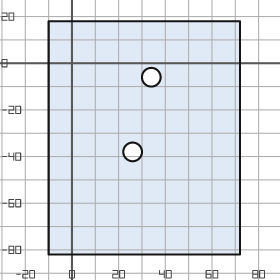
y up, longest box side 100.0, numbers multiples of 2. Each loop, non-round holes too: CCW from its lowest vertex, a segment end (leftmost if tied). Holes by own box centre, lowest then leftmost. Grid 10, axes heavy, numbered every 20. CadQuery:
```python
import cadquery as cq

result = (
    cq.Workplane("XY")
    .moveTo(-10.0, -82.0)
    .lineTo(72.0, -82.0)
    .lineTo(72.0, 18.0)
    .lineTo(-10.0, 18.0)
    .close()
    .moveTo(26.0, -38.0)
    .circle(4.0)
    .moveTo(34.0, -6.0)
    .circle(4.0)
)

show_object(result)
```